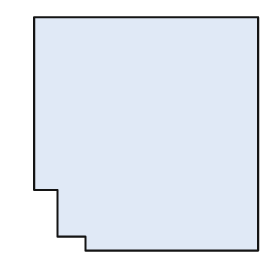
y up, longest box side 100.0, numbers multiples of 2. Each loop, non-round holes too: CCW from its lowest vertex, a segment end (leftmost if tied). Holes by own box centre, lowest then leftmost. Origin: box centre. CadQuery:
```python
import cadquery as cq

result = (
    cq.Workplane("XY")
    .moveTo(-26.0, -50.0)
    .lineTo(48.0, -50.0)
    .lineTo(48.0, 50.0)
    .lineTo(-48.0, 50.0)
    .lineTo(-48.0, -24.0)
    .lineTo(-38.0, -24.0)
    .lineTo(-38.0, -44.0)
    .lineTo(-26.0, -44.0)
    .close()
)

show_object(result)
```